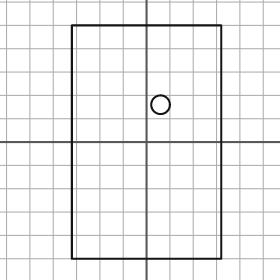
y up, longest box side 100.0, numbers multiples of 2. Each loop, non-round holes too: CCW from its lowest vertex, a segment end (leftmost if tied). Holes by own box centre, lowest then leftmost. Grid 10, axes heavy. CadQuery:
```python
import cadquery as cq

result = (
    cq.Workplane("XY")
    .moveTo(-32.0, -50.0)
    .lineTo(32.0, -50.0)
    .lineTo(32.0, 50.0)
    .lineTo(-32.0, 50.0)
    .close()
    .moveTo(6.0, 16.0)
    .circle(4.0)
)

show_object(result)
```